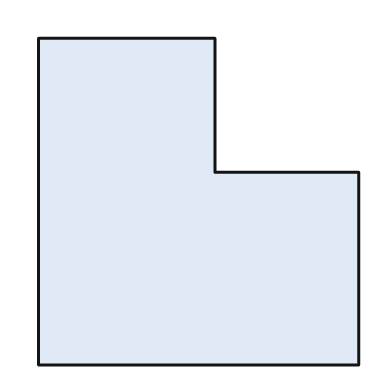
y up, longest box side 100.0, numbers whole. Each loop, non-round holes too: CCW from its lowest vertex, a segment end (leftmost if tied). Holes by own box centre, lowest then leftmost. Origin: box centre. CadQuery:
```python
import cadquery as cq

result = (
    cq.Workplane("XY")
    .moveTo(-49.0, -50.0)
    .lineTo(49.0, -50.0)
    .lineTo(49.0, 9.0)
    .lineTo(5.0, 9.0)
    .lineTo(5.0, 50.0)
    .lineTo(-49.0, 50.0)
    .close()
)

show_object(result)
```